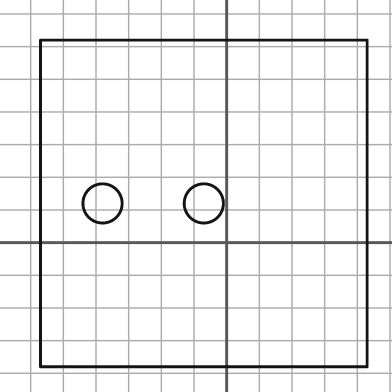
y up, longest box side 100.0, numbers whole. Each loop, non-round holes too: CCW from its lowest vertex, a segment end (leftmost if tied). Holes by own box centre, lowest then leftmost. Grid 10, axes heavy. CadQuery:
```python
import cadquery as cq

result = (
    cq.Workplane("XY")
    .moveTo(-57.0, -38.0)
    .lineTo(43.0, -38.0)
    .lineTo(43.0, 62.0)
    .lineTo(-57.0, 62.0)
    .close()
    .moveTo(-38.0, 12.0)
    .circle(6.0)
    .moveTo(-7.0, 12.0)
    .circle(6.0)
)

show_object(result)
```